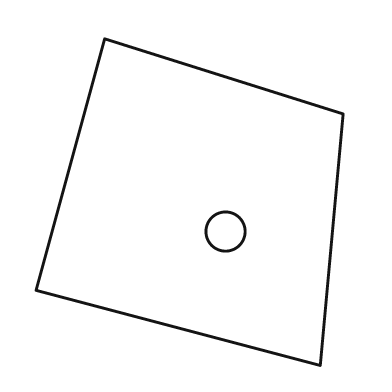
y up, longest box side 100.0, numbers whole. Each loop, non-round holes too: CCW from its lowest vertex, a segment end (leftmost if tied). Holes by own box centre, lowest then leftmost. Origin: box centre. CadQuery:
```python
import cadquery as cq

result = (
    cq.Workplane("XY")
    .moveTo(40.0, -50.0)
    .lineTo(47.0, 27.0)
    .lineTo(-26.0, 50.0)
    .lineTo(-47.0, -27.0)
    .close()
    .moveTo(11.0, -9.0)
    .circle(6.0)
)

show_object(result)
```